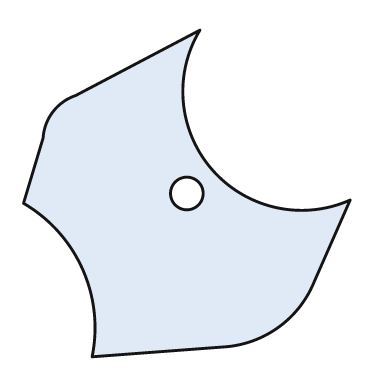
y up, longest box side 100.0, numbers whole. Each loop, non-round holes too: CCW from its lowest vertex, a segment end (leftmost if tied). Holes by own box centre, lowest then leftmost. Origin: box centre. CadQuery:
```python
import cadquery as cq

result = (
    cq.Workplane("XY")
    .moveTo(-29.0, -50.0)
    .lineTo(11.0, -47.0)
    .threePointArc((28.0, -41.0), (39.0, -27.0))
    .lineTo(50.0, -2.0)
    .threePointArc((8.0, 7.0), (4.0, 50.0))
    .lineTo(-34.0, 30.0)
    .threePointArc((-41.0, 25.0), (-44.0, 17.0))
    .lineTo(-50.0, -3.0)
    .threePointArc((-32.0, -23.0), (-29.0, -50.0))
    .close()
    .moveTo(0.0, 0.0)
    .circle(5.0)
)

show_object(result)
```